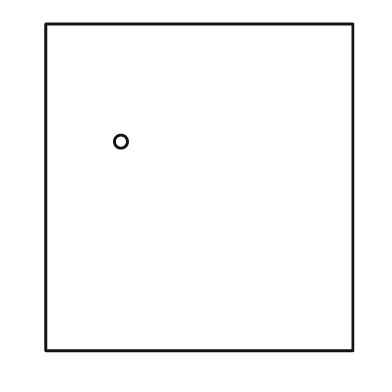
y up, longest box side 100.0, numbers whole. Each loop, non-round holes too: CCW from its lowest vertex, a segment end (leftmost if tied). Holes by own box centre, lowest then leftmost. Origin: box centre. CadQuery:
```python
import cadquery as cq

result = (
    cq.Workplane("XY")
    .moveTo(-47.0, -50.0)
    .lineTo(47.0, -50.0)
    .lineTo(47.0, 50.0)
    .lineTo(-47.0, 50.0)
    .close()
    .moveTo(-24.0, 14.0)
    .circle(2.0)
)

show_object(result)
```